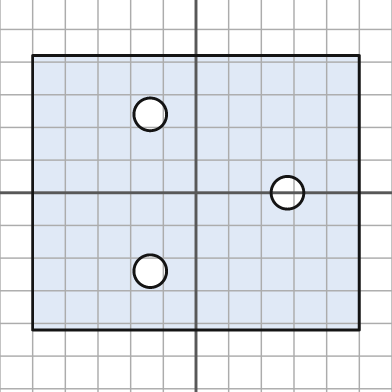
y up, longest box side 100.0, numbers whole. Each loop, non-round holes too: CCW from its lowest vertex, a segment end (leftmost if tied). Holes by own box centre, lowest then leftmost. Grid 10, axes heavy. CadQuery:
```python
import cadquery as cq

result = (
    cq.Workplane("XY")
    .moveTo(-50.0, -42.0)
    .lineTo(50.0, -42.0)
    .lineTo(50.0, 42.0)
    .lineTo(-50.0, 42.0)
    .close()
    .moveTo(-14.0, -24.0)
    .circle(5.0)
    .moveTo(28.0, 0.0)
    .circle(5.0)
    .moveTo(-14.0, 24.0)
    .circle(5.0)
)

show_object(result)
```